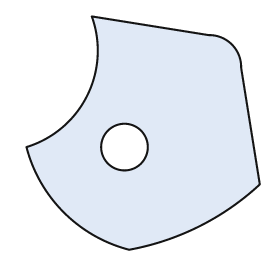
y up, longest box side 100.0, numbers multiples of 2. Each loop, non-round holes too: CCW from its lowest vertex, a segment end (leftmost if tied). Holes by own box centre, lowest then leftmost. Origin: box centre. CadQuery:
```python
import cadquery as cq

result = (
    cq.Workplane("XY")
    .moveTo(-6.0, -50.0)
    .threePointArc((24.0, -40.0), (50.0, -22.0))
    .lineTo(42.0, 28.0)
    .threePointArc((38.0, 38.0), (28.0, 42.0))
    .lineTo(-22.0, 50.0)
    .threePointArc((-24.0, 16.0), (-50.0, -6.0))
    .threePointArc((-34.0, -34.0), (-6.0, -50.0))
    .close()
    .moveTo(-8.0, -6.0)
    .circle(10.0)
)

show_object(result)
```